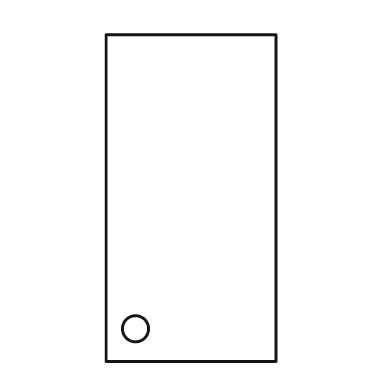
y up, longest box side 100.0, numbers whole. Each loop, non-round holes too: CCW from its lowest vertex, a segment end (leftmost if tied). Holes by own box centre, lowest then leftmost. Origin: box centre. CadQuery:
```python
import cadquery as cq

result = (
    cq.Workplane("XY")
    .moveTo(-26.0, -50.0)
    .lineTo(26.0, -50.0)
    .lineTo(26.0, 50.0)
    .lineTo(-26.0, 50.0)
    .close()
    .moveTo(-17.0, -40.0)
    .circle(4.0)
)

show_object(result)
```